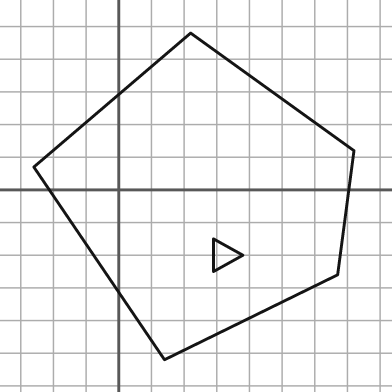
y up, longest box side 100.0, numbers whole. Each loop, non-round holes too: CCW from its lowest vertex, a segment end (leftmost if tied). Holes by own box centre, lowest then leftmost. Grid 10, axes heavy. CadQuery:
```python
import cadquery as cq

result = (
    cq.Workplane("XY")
    .moveTo(14.0, -52.0)
    .lineTo(67.0, -26.0)
    .lineTo(72.0, 12.0)
    .lineTo(22.0, 48.0)
    .lineTo(-26.0, 7.0)
    .close()
    .moveTo(29.0, -25.0)
    .lineTo(38.0, -20.0)
    .lineTo(29.0, -15.0)
    .close()
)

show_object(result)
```